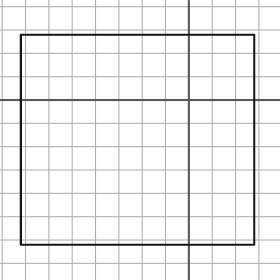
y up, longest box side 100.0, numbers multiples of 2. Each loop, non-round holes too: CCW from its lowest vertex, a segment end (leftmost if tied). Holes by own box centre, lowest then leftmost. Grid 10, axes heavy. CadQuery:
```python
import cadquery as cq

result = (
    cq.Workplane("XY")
    .moveTo(-72.0, -62.0)
    .lineTo(28.0, -62.0)
    .lineTo(28.0, 28.0)
    .lineTo(-72.0, 28.0)
    .close()
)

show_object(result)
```